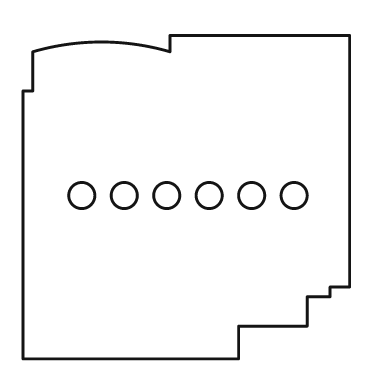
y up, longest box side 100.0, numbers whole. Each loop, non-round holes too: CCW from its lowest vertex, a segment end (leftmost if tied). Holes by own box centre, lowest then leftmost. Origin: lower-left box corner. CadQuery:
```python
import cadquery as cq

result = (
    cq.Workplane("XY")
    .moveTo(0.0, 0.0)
    .lineTo(66.0, 0.0)
    .lineTo(66.0, 10.0)
    .lineTo(87.0, 10.0)
    .lineTo(87.0, 19.0)
    .lineTo(94.0, 19.0)
    .lineTo(94.0, 22.0)
    .lineTo(100.0, 22.0)
    .lineTo(100.0, 99.0)
    .lineTo(45.0, 99.0)
    .lineTo(45.0, 94.0)
    .threePointArc((24.0, 97.0), (3.0, 94.0))
    .lineTo(3.0, 82.0)
    .lineTo(0.0, 82.0)
    .close()
    .moveTo(18.0, 50.0)
    .circle(4.0)
    .moveTo(31.0, 50.0)
    .circle(4.0)
    .moveTo(44.0, 50.0)
    .circle(4.0)
    .moveTo(57.0, 50.0)
    .circle(4.0)
    .moveTo(70.0, 50.0)
    .circle(4.0)
    .moveTo(83.0, 50.0)
    .circle(4.0)
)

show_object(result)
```